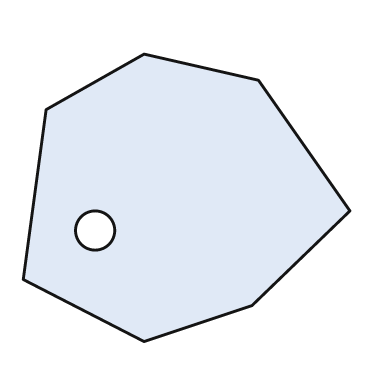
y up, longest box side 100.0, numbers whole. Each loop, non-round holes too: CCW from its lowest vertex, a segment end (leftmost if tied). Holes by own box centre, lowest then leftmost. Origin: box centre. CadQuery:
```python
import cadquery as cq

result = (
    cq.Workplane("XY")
    .moveTo(-13.0, -44.0)
    .lineTo(20.0, -33.0)
    .lineTo(50.0, -4.0)
    .lineTo(22.0, 36.0)
    .lineTo(-13.0, 44.0)
    .lineTo(-43.0, 27.0)
    .lineTo(-50.0, -25.0)
    .close()
    .moveTo(-28.0, -10.0)
    .circle(6.0)
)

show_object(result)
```